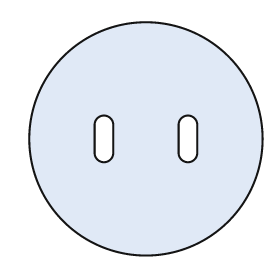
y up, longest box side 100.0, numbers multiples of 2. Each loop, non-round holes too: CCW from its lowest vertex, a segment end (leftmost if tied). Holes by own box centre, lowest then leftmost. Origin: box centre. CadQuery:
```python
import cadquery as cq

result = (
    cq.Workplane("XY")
    .moveTo(0.0, 0.0)
    .circle(50.0)
    .moveTo(-22.0, -6.0)
    .threePointArc((-18.0, -10.0), (-14.0, -6.0))
    .lineTo(-14.0, 6.0)
    .threePointArc((-18.0, 10.0), (-22.0, 6.0))
    .close()
    .moveTo(14.0, -6.0)
    .threePointArc((18.0, -10.0), (22.0, -6.0))
    .lineTo(22.0, 6.0)
    .threePointArc((18.0, 10.0), (14.0, 6.0))
    .close()
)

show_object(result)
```